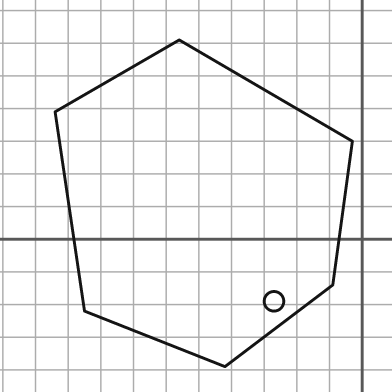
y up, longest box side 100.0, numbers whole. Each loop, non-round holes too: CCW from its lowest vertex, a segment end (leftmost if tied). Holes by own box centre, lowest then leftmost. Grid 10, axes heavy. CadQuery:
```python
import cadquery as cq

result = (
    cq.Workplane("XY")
    .moveTo(-42.0, -39.0)
    .lineTo(-9.0, -14.0)
    .lineTo(-3.0, 30.0)
    .lineTo(-56.0, 61.0)
    .lineTo(-94.0, 39.0)
    .lineTo(-85.0, -22.0)
    .close()
    .moveTo(-27.0, -19.0)
    .circle(3.0)
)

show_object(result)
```